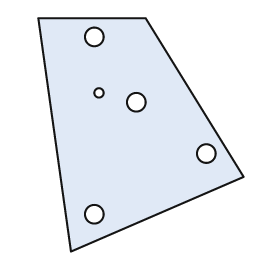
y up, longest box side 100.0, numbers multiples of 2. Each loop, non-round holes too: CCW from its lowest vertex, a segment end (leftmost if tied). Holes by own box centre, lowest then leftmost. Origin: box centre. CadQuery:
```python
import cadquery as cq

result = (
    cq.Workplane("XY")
    .moveTo(-30.0, -50.0)
    .lineTo(44.0, -18.0)
    .lineTo(2.0, 50.0)
    .lineTo(-44.0, 50.0)
    .close()
    .moveTo(-20.0, -34.0)
    .circle(4.0)
    .moveTo(28.0, -8.0)
    .circle(4.0)
    .moveTo(-2.0, 14.0)
    .circle(4.0)
    .moveTo(-18.0, 18.0)
    .circle(2.0)
    .moveTo(-20.0, 42.0)
    .circle(4.0)
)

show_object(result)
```